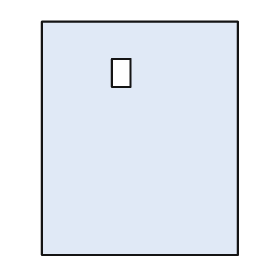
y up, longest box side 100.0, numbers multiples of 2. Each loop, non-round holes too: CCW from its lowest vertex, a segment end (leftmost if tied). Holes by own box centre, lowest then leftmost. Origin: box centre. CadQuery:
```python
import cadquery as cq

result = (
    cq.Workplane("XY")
    .moveTo(-42.0, -50.0)
    .lineTo(42.0, -50.0)
    .lineTo(42.0, 50.0)
    .lineTo(-42.0, 50.0)
    .close()
    .moveTo(-12.0, 22.0)
    .lineTo(-4.0, 22.0)
    .lineTo(-4.0, 34.0)
    .lineTo(-12.0, 34.0)
    .close()
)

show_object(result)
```